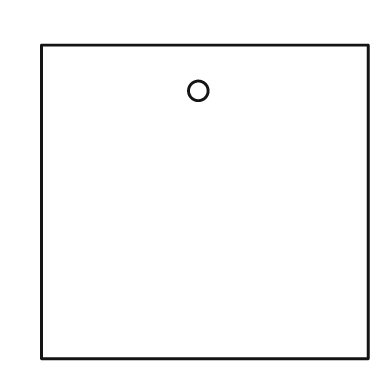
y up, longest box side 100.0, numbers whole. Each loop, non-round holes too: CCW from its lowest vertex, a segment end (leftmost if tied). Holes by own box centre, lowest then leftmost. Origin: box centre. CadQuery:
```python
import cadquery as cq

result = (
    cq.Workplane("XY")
    .moveTo(-50.0, -48.0)
    .lineTo(50.0, -48.0)
    .lineTo(50.0, 48.0)
    .lineTo(-50.0, 48.0)
    .close()
    .moveTo(-2.0, 34.0)
    .circle(3.0)
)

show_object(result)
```